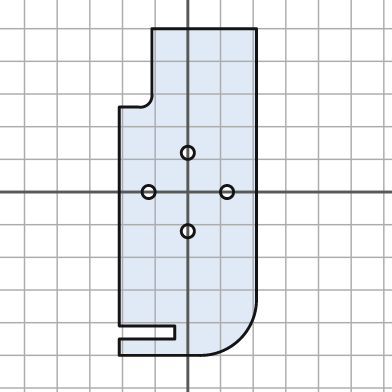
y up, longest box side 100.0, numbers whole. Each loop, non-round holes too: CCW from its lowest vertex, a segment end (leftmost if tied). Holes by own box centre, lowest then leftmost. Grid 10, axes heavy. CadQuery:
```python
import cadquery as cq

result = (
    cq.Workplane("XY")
    .moveTo(-21.0, -50.0)
    .lineTo(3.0, -50.0)
    .threePointArc((16.0, -45.0), (21.0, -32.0))
    .lineTo(21.0, 50.0)
    .lineTo(-11.0, 50.0)
    .lineTo(-11.0, 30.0)
    .threePointArc((-12.0, 27.0), (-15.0, 26.0))
    .lineTo(-21.0, 26.0)
    .lineTo(-21.0, -41.0)
    .lineTo(-4.0, -41.0)
    .lineTo(-4.0, -45.0)
    .lineTo(-21.0, -45.0)
    .close()
    .moveTo(0.0, -12.0)
    .circle(2.0)
    .moveTo(-12.0, 0.0)
    .circle(2.0)
    .moveTo(12.0, 0.0)
    .circle(2.0)
    .moveTo(0.0, 12.0)
    .circle(2.0)
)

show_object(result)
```